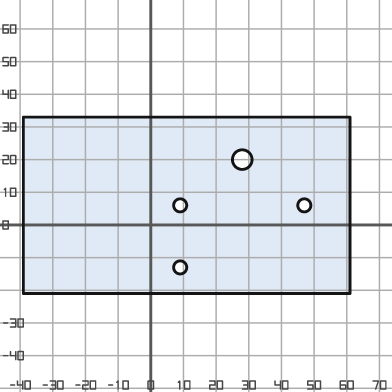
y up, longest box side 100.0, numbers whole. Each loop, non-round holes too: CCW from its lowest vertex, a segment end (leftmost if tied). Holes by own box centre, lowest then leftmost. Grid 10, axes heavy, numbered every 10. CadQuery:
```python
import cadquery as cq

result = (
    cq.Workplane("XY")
    .moveTo(-39.0, -21.0)
    .lineTo(61.0, -21.0)
    .lineTo(61.0, 33.0)
    .lineTo(-39.0, 33.0)
    .close()
    .moveTo(9.0, -13.0)
    .circle(2.0)
    .moveTo(9.0, 6.0)
    .circle(2.0)
    .moveTo(47.0, 6.0)
    .circle(2.0)
    .moveTo(28.0, 20.0)
    .circle(3.0)
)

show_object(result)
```